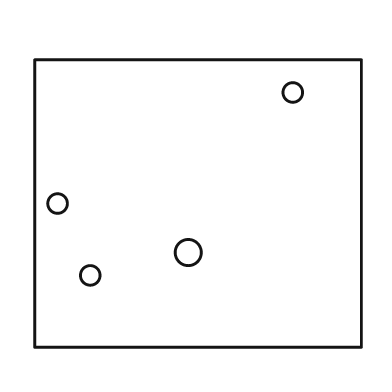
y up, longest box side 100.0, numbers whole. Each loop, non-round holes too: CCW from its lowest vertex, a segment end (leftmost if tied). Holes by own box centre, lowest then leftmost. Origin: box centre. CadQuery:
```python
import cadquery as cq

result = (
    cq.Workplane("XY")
    .moveTo(-50.0, -44.0)
    .lineTo(50.0, -44.0)
    .lineTo(50.0, 44.0)
    .lineTo(-50.0, 44.0)
    .close()
    .moveTo(-33.0, -22.0)
    .circle(3.0)
    .moveTo(-3.0, -15.0)
    .circle(4.0)
    .moveTo(-43.0, 0.0)
    .circle(3.0)
    .moveTo(29.0, 34.0)
    .circle(3.0)
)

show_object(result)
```